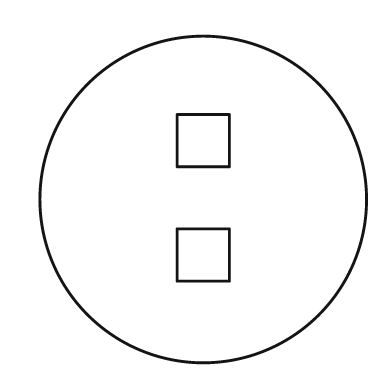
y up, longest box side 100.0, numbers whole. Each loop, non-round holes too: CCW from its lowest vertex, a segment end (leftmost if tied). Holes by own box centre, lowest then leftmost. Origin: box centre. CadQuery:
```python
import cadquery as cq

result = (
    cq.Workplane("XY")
    .moveTo(0.0, 0.0)
    .circle(50.0)
    .moveTo(-8.0, -25.0)
    .lineTo(8.0, -25.0)
    .lineTo(8.0, -9.0)
    .lineTo(-8.0, -9.0)
    .close()
    .moveTo(-8.0, 10.0)
    .lineTo(8.0, 10.0)
    .lineTo(8.0, 26.0)
    .lineTo(-8.0, 26.0)
    .close()
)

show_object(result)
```